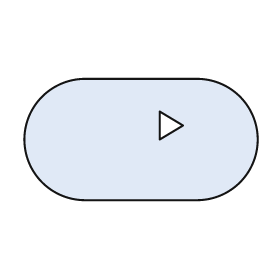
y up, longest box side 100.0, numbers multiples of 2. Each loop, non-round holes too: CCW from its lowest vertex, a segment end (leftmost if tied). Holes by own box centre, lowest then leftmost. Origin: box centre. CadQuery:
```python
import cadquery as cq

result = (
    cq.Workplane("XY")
    .moveTo(-24.0, -26.0)
    .lineTo(24.0, -26.0)
    .threePointArc((50.0, 0.0), (24.0, 26.0))
    .lineTo(-24.0, 26.0)
    .threePointArc((-50.0, 0.0), (-24.0, -26.0))
    .close()
    .moveTo(8.0, 0.0)
    .lineTo(18.0, 6.0)
    .lineTo(8.0, 12.0)
    .close()
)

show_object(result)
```